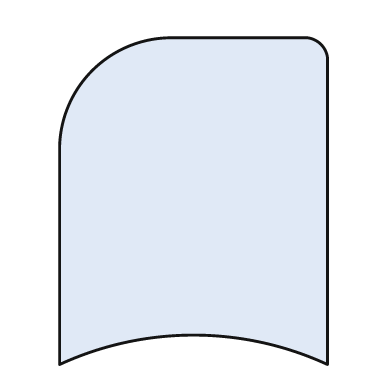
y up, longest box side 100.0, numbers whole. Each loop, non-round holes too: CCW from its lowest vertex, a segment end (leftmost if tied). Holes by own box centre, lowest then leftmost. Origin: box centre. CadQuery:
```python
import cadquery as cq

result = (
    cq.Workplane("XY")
    .moveTo(-41.0, -50.0)
    .threePointArc((0.0, -41.0), (41.0, -50.0))
    .lineTo(41.0, 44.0)
    .threePointArc((39.0, 48.0), (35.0, 50.0))
    .lineTo(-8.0, 50.0)
    .threePointArc((-31.0, 40.0), (-41.0, 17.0))
    .close()
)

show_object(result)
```